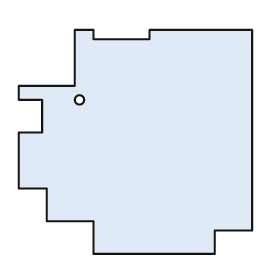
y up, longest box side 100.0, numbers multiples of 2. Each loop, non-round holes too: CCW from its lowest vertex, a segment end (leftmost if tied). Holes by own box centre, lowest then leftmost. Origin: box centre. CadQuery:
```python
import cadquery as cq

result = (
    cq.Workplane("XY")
    .moveTo(-18.0, -48.0)
    .lineTo(34.0, -48.0)
    .lineTo(34.0, -38.0)
    .lineTo(50.0, -38.0)
    .lineTo(50.0, 48.0)
    .lineTo(6.0, 48.0)
    .lineTo(6.0, 44.0)
    .lineTo(-18.0, 44.0)
    .lineTo(-18.0, 48.0)
    .lineTo(-26.0, 48.0)
    .lineTo(-26.0, 24.0)
    .lineTo(-50.0, 24.0)
    .lineTo(-50.0, 18.0)
    .lineTo(-40.0, 18.0)
    .lineTo(-40.0, 4.0)
    .lineTo(-50.0, 4.0)
    .lineTo(-50.0, -20.0)
    .lineTo(-38.0, -20.0)
    .lineTo(-38.0, -34.0)
    .lineTo(-18.0, -34.0)
    .close()
    .moveTo(-24.0, 18.0)
    .circle(2.0)
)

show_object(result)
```